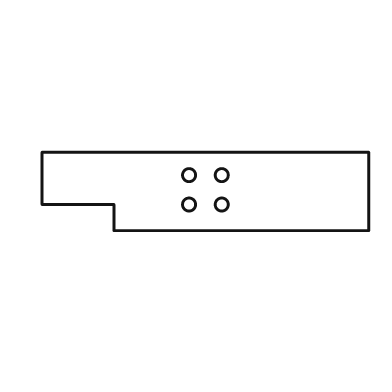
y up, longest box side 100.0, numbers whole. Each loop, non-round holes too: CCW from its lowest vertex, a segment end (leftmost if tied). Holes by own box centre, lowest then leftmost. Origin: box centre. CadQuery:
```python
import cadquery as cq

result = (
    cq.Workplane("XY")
    .moveTo(-28.0, -12.0)
    .lineTo(50.0, -12.0)
    .lineTo(50.0, 12.0)
    .lineTo(-50.0, 12.0)
    .lineTo(-50.0, -4.0)
    .lineTo(-28.0, -4.0)
    .close()
    .moveTo(-5.0, -4.0)
    .circle(2.0)
    .moveTo(5.0, -4.0)
    .circle(2.0)
    .moveTo(-5.0, 5.0)
    .circle(2.0)
    .moveTo(5.0, 5.0)
    .circle(2.0)
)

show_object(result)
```